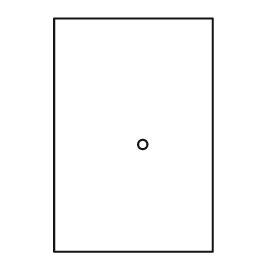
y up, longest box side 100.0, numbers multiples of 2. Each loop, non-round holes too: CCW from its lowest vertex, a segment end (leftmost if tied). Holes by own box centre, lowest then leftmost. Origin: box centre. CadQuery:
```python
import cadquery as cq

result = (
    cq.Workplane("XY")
    .moveTo(-34.0, -50.0)
    .lineTo(34.0, -50.0)
    .lineTo(34.0, 50.0)
    .lineTo(-34.0, 50.0)
    .close()
    .moveTo(4.0, -4.0)
    .circle(2.0)
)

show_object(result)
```